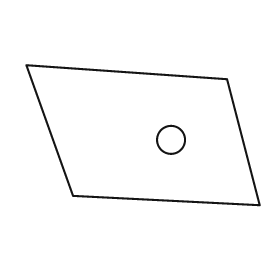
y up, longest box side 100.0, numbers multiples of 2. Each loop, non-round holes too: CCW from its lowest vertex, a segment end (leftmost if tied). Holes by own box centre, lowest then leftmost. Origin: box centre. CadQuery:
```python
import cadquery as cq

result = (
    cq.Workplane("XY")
    .moveTo(50.0, -30.0)
    .lineTo(36.0, 24.0)
    .lineTo(-50.0, 30.0)
    .lineTo(-30.0, -26.0)
    .close()
    .moveTo(12.0, -2.0)
    .circle(6.0)
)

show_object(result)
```